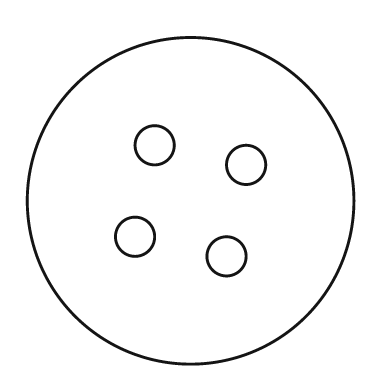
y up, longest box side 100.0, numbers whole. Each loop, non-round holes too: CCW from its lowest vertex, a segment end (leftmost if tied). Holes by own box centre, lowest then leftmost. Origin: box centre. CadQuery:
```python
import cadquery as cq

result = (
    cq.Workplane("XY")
    .moveTo(0.0, 0.0)
    .circle(50.0)
    .moveTo(11.0, -17.0)
    .circle(6.0)
    .moveTo(-17.0, -11.0)
    .circle(6.0)
    .moveTo(17.0, 11.0)
    .circle(6.0)
    .moveTo(-11.0, 17.0)
    .circle(6.0)
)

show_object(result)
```